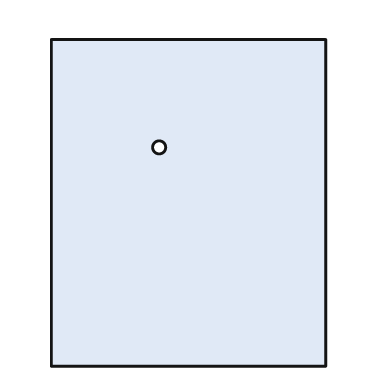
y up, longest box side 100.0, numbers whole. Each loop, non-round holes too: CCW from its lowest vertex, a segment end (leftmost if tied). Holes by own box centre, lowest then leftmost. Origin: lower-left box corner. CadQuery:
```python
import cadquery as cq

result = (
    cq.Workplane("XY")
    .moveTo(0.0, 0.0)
    .lineTo(84.0, 0.0)
    .lineTo(84.0, 100.0)
    .lineTo(0.0, 100.0)
    .close()
    .moveTo(33.0, 67.0)
    .circle(2.0)
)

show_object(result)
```